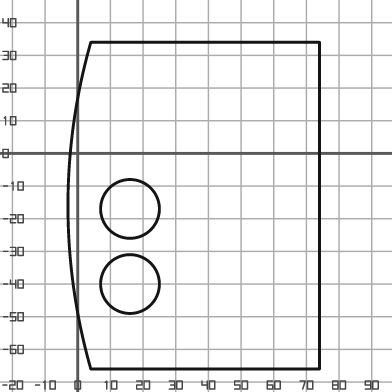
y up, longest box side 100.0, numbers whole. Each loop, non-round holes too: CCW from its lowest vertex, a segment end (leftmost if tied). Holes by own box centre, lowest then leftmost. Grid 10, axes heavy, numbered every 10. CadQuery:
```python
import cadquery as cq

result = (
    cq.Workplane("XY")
    .moveTo(4.0, -66.0)
    .lineTo(74.0, -66.0)
    .lineTo(74.0, 34.0)
    .lineTo(4.0, 34.0)
    .threePointArc((-3.0, -16.0), (4.0, -66.0))
    .close()
    .moveTo(16.0, -40.0)
    .circle(9.0)
    .moveTo(16.0, -17.0)
    .circle(9.0)
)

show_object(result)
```